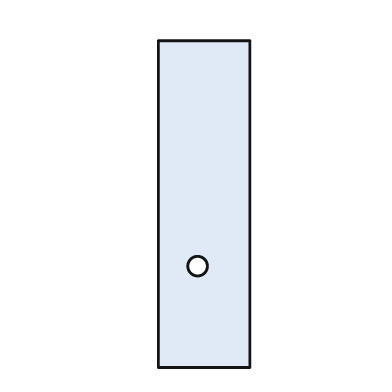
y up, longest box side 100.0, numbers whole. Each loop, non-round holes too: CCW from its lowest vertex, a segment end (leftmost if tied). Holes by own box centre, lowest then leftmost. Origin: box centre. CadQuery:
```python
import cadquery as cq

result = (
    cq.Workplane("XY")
    .moveTo(-14.0, -50.0)
    .lineTo(14.0, -50.0)
    .lineTo(14.0, 50.0)
    .lineTo(-14.0, 50.0)
    .close()
    .moveTo(-2.0, -19.0)
    .circle(3.0)
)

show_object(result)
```